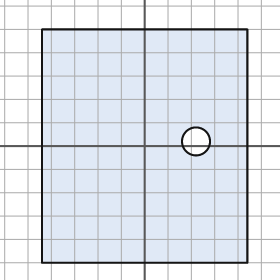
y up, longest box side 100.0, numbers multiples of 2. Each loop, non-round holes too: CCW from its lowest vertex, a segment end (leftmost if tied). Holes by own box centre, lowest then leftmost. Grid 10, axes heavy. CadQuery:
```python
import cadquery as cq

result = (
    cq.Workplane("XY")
    .moveTo(-44.0, -50.0)
    .lineTo(44.0, -50.0)
    .lineTo(44.0, 50.0)
    .lineTo(-44.0, 50.0)
    .close()
    .moveTo(22.0, 2.0)
    .circle(6.0)
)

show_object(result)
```